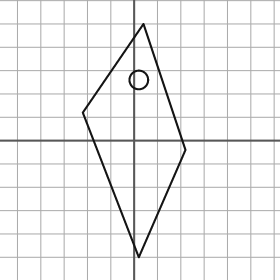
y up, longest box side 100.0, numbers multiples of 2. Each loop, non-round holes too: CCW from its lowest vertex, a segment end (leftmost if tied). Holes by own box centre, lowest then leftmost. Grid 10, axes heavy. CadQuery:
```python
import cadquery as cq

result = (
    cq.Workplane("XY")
    .moveTo(2.0, -50.0)
    .lineTo(22.0, -4.0)
    .lineTo(4.0, 50.0)
    .lineTo(-22.0, 12.0)
    .close()
    .moveTo(2.0, 26.0)
    .circle(4.0)
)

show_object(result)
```